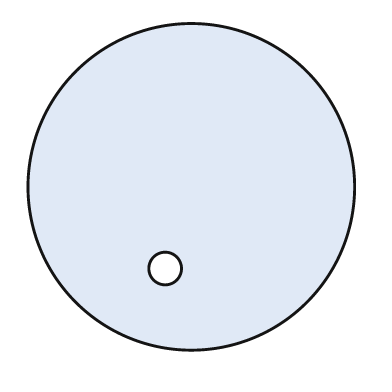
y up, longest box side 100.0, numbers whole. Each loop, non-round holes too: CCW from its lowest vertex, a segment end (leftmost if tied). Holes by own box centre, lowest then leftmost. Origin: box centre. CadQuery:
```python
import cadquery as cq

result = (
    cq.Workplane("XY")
    .moveTo(0.0, 0.0)
    .circle(50.0)
    .moveTo(-8.0, -25.0)
    .circle(5.0)
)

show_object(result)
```